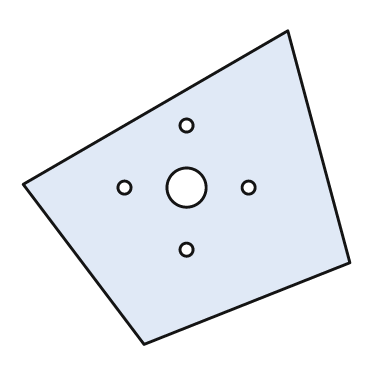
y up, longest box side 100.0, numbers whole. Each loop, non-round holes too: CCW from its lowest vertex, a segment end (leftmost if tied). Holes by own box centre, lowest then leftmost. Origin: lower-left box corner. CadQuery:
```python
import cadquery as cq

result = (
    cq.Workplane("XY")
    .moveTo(37.0, 0.0)
    .lineTo(100.0, 25.0)
    .lineTo(81.0, 96.0)
    .lineTo(0.0, 49.0)
    .close()
    .moveTo(50.0, 29.0)
    .circle(2.0)
    .moveTo(31.0, 48.0)
    .circle(2.0)
    .moveTo(50.0, 48.0)
    .circle(6.0)
    .moveTo(69.0, 48.0)
    .circle(2.0)
    .moveTo(50.0, 67.0)
    .circle(2.0)
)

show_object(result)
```